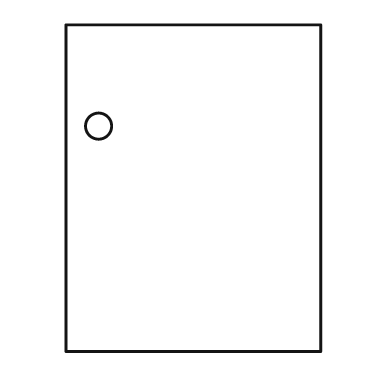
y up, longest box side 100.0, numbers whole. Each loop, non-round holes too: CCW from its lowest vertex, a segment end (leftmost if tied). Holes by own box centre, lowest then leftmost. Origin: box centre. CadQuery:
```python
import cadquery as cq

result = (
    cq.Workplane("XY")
    .moveTo(-39.0, -50.0)
    .lineTo(39.0, -50.0)
    .lineTo(39.0, 50.0)
    .lineTo(-39.0, 50.0)
    .close()
    .moveTo(-29.0, 19.0)
    .circle(4.0)
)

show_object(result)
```